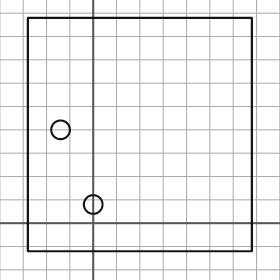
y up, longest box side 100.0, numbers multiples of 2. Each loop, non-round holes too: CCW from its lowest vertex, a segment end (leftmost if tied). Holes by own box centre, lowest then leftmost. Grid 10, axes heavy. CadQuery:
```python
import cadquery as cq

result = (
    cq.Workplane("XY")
    .moveTo(-28.0, -12.0)
    .lineTo(68.0, -12.0)
    .lineTo(68.0, 88.0)
    .lineTo(-28.0, 88.0)
    .close()
    .moveTo(0.0, 8.0)
    .circle(4.0)
    .moveTo(-14.0, 40.0)
    .circle(4.0)
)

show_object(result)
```